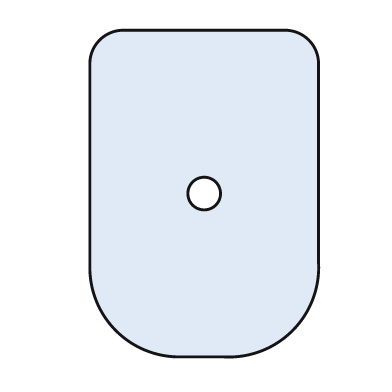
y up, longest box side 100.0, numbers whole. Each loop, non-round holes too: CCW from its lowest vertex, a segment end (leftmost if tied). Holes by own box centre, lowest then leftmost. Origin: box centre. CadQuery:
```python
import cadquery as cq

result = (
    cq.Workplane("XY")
    .moveTo(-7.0, -50.0)
    .lineTo(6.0, -50.0)
    .threePointArc((27.0, -42.0), (35.0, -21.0))
    .lineTo(35.0, 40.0)
    .threePointArc((32.0, 47.0), (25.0, 50.0))
    .lineTo(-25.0, 50.0)
    .threePointArc((-32.0, 47.0), (-35.0, 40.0))
    .lineTo(-35.0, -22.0)
    .threePointArc((-27.0, -42.0), (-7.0, -50.0))
    .close()
    .moveTo(0.0, 0.0)
    .circle(5.0)
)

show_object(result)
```